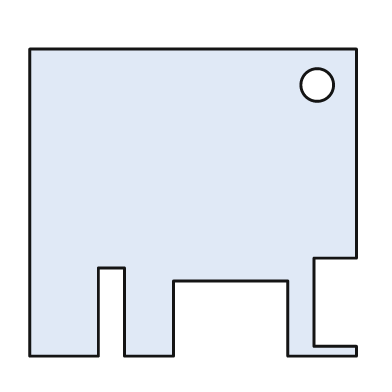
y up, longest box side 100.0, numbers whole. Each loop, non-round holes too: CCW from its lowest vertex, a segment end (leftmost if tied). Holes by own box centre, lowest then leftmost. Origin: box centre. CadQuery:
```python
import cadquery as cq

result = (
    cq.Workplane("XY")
    .moveTo(-50.0, -47.0)
    .lineTo(-29.0, -47.0)
    .lineTo(-29.0, -20.0)
    .lineTo(-21.0, -20.0)
    .lineTo(-21.0, -47.0)
    .lineTo(-6.0, -47.0)
    .lineTo(-6.0, -24.0)
    .lineTo(29.0, -24.0)
    .lineTo(29.0, -47.0)
    .lineTo(50.0, -47.0)
    .lineTo(50.0, -44.0)
    .lineTo(37.0, -44.0)
    .lineTo(37.0, -17.0)
    .lineTo(50.0, -17.0)
    .lineTo(50.0, 47.0)
    .lineTo(-50.0, 47.0)
    .close()
    .moveTo(38.0, 36.0)
    .circle(5.0)
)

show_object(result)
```